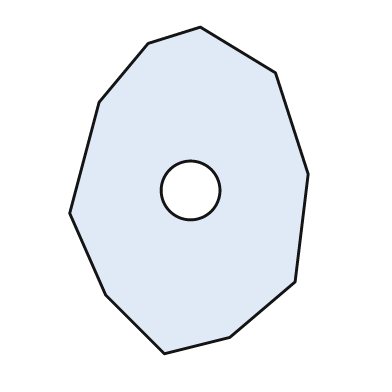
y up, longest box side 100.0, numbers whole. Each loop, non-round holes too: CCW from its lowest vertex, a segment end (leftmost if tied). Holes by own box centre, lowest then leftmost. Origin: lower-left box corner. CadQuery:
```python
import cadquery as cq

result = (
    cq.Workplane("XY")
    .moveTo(29.0, 0.0)
    .lineTo(49.0, 5.0)
    .lineTo(69.0, 22.0)
    .lineTo(73.0, 55.0)
    .lineTo(63.0, 86.0)
    .lineTo(40.0, 100.0)
    .lineTo(24.0, 95.0)
    .lineTo(9.0, 77.0)
    .lineTo(0.0, 43.0)
    .lineTo(11.0, 18.0)
    .close()
    .moveTo(37.0, 50.0)
    .circle(9.0)
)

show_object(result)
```